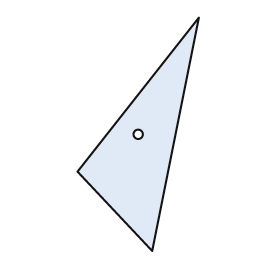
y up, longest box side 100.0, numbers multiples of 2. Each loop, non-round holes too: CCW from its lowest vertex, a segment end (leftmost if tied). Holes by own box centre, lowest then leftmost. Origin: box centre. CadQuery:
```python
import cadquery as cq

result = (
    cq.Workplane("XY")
    .moveTo(6.0, -50.0)
    .lineTo(26.0, 50.0)
    .lineTo(-26.0, -16.0)
    .close()
    .moveTo(0.0, 0.0)
    .circle(2.0)
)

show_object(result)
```